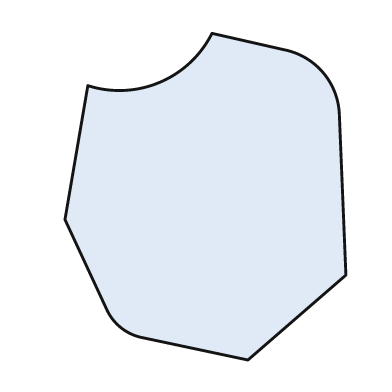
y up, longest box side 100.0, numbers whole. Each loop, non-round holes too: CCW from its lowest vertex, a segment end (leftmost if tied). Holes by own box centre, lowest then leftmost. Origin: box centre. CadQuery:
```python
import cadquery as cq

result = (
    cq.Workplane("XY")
    .moveTo(13.0, -50.0)
    .lineTo(43.0, -24.0)
    .lineTo(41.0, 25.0)
    .threePointArc((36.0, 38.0), (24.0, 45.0))
    .lineTo(2.0, 50.0)
    .threePointArc((-14.0, 35.0), (-36.0, 34.0))
    .lineTo(-43.0, -7.0)
    .lineTo(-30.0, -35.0)
    .threePointArc((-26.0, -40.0), (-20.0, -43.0))
    .close()
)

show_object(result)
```